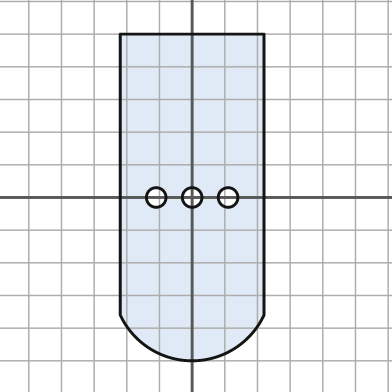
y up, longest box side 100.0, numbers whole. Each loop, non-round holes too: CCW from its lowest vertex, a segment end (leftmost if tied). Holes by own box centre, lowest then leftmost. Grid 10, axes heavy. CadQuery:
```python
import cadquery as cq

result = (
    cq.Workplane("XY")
    .moveTo(-22.0, -36.0)
    .threePointArc((0.0, -50.0), (22.0, -36.0))
    .lineTo(22.0, 50.0)
    .lineTo(-22.0, 50.0)
    .close()
    .moveTo(-11.0, 0.0)
    .circle(3.0)
    .moveTo(0.0, 0.0)
    .circle(3.0)
    .moveTo(11.0, 0.0)
    .circle(3.0)
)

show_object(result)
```